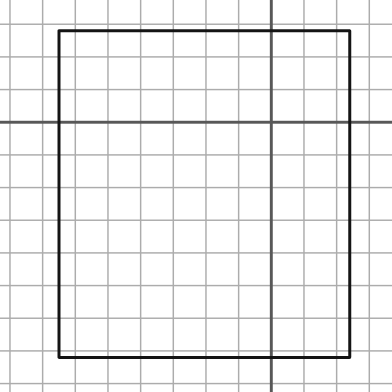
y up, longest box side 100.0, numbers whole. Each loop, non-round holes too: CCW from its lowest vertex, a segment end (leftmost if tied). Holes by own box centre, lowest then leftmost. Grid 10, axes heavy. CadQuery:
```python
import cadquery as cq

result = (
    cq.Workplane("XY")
    .moveTo(-65.0, -72.0)
    .lineTo(24.0, -72.0)
    .lineTo(24.0, 28.0)
    .lineTo(-65.0, 28.0)
    .close()
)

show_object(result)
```